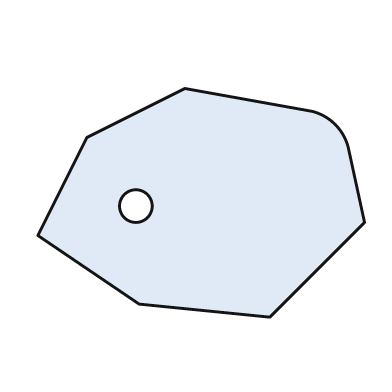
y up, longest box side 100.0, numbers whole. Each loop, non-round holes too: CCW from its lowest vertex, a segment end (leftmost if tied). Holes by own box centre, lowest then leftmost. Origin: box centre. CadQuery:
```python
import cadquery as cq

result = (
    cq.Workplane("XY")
    .moveTo(21.0, -35.0)
    .lineTo(50.0, -6.0)
    .lineTo(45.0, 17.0)
    .threePointArc((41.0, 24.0), (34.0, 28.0))
    .lineTo(-5.0, 35.0)
    .lineTo(-35.0, 20.0)
    .lineTo(-50.0, -10.0)
    .lineTo(-19.0, -31.0)
    .close()
    .moveTo(-20.0, -1.0)
    .circle(5.0)
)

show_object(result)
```